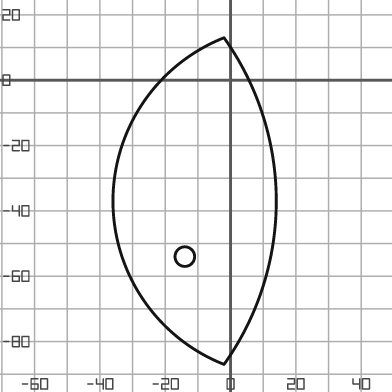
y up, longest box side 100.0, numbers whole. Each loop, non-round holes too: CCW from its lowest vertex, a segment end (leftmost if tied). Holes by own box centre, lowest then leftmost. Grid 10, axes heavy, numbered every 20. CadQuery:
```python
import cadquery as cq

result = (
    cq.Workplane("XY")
    .moveTo(-2.0, -87.0)
    .threePointArc((14.0, -37.0), (-2.0, 13.0))
    .threePointArc((-36.0, -37.0), (-2.0, -87.0))
    .close()
    .moveTo(-14.0, -54.0)
    .circle(3.0)
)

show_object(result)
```